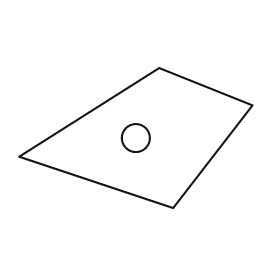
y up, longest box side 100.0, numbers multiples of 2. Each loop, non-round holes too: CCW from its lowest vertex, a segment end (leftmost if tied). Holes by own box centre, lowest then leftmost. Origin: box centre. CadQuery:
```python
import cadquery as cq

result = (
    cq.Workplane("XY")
    .moveTo(16.0, -30.0)
    .lineTo(50.0, 14.0)
    .lineTo(10.0, 30.0)
    .lineTo(-50.0, -8.0)
    .close()
    .moveTo(0.0, 0.0)
    .circle(6.0)
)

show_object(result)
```